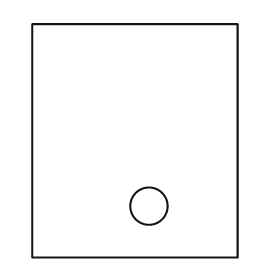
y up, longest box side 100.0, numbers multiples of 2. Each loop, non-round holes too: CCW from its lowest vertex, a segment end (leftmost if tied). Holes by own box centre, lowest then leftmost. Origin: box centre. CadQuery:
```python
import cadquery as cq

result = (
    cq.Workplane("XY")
    .moveTo(-44.0, -50.0)
    .lineTo(44.0, -50.0)
    .lineTo(44.0, 50.0)
    .lineTo(-44.0, 50.0)
    .close()
    .moveTo(6.0, -28.0)
    .circle(8.0)
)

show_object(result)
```